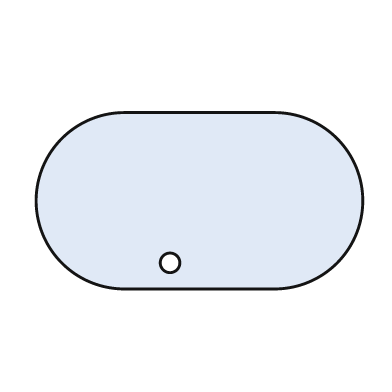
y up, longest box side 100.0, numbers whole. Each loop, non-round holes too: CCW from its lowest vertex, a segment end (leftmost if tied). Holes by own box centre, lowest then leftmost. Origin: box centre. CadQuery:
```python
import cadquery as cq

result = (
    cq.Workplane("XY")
    .moveTo(-23.0, -27.0)
    .lineTo(23.0, -27.0)
    .threePointArc((50.0, 0.0), (23.0, 27.0))
    .lineTo(-23.0, 27.0)
    .threePointArc((-50.0, 0.0), (-23.0, -27.0))
    .close()
    .moveTo(-9.0, -19.0)
    .circle(3.0)
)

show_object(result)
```